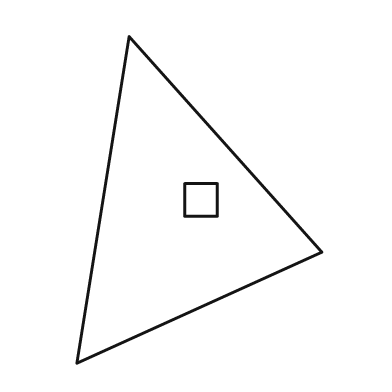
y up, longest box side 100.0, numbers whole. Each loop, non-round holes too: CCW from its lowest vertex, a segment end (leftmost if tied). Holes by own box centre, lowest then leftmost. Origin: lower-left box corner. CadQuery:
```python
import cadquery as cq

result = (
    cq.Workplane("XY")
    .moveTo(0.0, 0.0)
    .lineTo(75.0, 34.0)
    .lineTo(16.0, 100.0)
    .close()
    .moveTo(33.0, 45.0)
    .lineTo(43.0, 45.0)
    .lineTo(43.0, 55.0)
    .lineTo(33.0, 55.0)
    .close()
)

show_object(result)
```